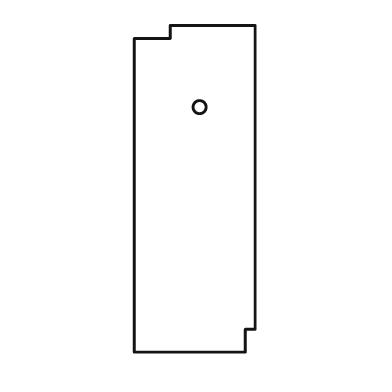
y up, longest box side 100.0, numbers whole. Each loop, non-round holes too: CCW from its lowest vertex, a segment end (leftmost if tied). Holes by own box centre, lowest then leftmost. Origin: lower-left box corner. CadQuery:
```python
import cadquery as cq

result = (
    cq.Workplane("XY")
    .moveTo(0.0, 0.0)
    .lineTo(34.0, 0.0)
    .lineTo(34.0, 7.0)
    .lineTo(37.0, 7.0)
    .lineTo(37.0, 100.0)
    .lineTo(11.0, 100.0)
    .lineTo(11.0, 96.0)
    .lineTo(0.0, 96.0)
    .close()
    .moveTo(20.0, 75.0)
    .circle(2.0)
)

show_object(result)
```